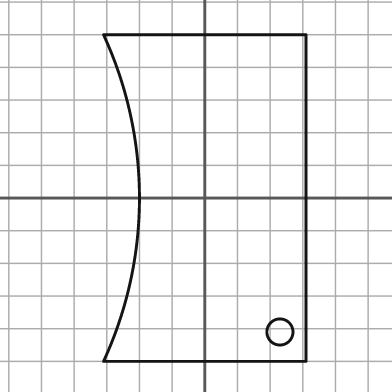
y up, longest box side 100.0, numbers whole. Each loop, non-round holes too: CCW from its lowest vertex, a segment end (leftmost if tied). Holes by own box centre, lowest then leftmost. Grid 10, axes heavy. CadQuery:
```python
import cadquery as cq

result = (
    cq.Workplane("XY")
    .moveTo(-31.0, -50.0)
    .lineTo(31.0, -50.0)
    .lineTo(31.0, 50.0)
    .lineTo(-31.0, 50.0)
    .threePointArc((-20.0, 0.0), (-31.0, -50.0))
    .close()
    .moveTo(23.0, -41.0)
    .circle(4.0)
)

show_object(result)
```